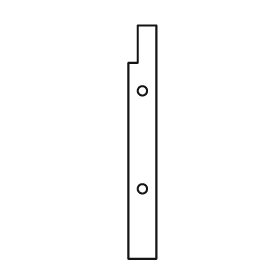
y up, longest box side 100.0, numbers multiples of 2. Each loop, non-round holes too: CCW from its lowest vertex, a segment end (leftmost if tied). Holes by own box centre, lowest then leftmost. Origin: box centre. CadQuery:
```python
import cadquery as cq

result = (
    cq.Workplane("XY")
    .moveTo(-6.0, -50.0)
    .lineTo(6.0, -50.0)
    .lineTo(6.0, 50.0)
    .lineTo(-2.0, 50.0)
    .lineTo(-2.0, 34.0)
    .lineTo(-6.0, 34.0)
    .close()
    .moveTo(0.0, -20.0)
    .circle(2.0)
    .moveTo(0.0, 22.0)
    .circle(2.0)
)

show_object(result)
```